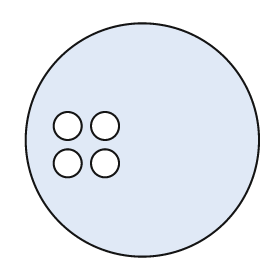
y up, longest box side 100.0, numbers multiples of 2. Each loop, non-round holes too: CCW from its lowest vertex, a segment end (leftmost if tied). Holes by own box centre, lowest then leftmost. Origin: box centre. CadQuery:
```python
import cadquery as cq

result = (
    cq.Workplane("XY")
    .moveTo(0.0, 0.0)
    .circle(50.0)
    .moveTo(-32.0, -10.0)
    .circle(6.0)
    .moveTo(-16.0, -10.0)
    .circle(6.0)
    .moveTo(-32.0, 6.0)
    .circle(6.0)
    .moveTo(-16.0, 6.0)
    .circle(6.0)
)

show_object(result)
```